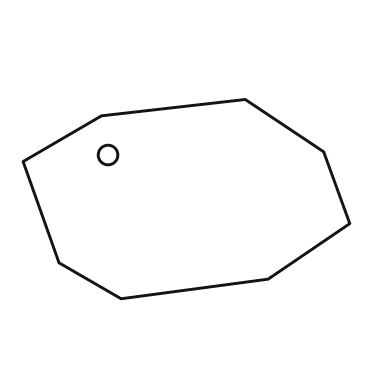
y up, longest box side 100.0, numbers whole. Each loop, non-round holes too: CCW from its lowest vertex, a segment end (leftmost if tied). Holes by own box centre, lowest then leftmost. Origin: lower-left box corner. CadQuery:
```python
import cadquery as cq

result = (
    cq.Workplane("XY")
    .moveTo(30.0, 0.0)
    .lineTo(75.0, 6.0)
    .lineTo(100.0, 23.0)
    .lineTo(92.0, 45.0)
    .lineTo(68.0, 61.0)
    .lineTo(24.0, 56.0)
    .lineTo(0.0, 42.0)
    .lineTo(11.0, 11.0)
    .close()
    .moveTo(26.0, 44.0)
    .circle(3.0)
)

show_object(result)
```